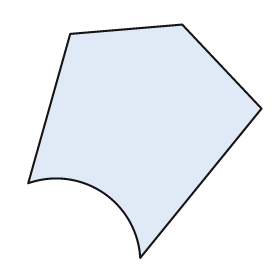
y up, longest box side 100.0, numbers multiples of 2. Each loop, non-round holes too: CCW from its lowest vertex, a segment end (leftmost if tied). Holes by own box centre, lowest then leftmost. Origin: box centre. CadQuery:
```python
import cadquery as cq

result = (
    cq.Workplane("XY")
    .moveTo(-2.0, -50.0)
    .lineTo(50.0, 14.0)
    .lineTo(16.0, 50.0)
    .lineTo(-32.0, 46.0)
    .lineTo(-50.0, -18.0)
    .threePointArc((-18.0, -22.0), (-2.0, -50.0))
    .close()
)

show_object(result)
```